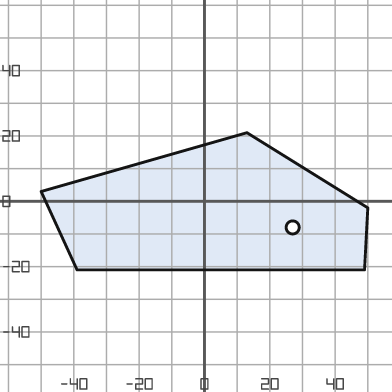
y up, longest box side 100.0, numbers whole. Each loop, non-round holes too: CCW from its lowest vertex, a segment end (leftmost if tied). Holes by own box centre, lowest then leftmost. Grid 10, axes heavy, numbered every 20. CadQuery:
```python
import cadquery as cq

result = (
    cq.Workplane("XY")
    .moveTo(-39.0, -21.0)
    .lineTo(49.0, -21.0)
    .lineTo(50.0, -2.0)
    .lineTo(13.0, 21.0)
    .lineTo(-50.0, 3.0)
    .close()
    .moveTo(27.0, -8.0)
    .circle(2.0)
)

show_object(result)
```